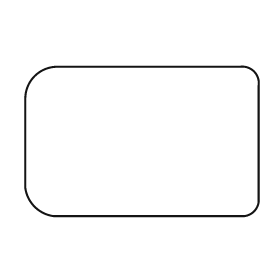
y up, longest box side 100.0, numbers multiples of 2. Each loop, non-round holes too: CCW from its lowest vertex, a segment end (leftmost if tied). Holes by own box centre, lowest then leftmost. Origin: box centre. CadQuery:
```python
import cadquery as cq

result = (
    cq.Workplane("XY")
    .moveTo(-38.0, -32.0)
    .lineTo(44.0, -32.0)
    .threePointArc((48.0, -30.0), (50.0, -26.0))
    .lineTo(50.0, 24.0)
    .threePointArc((48.0, 30.0), (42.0, 32.0))
    .lineTo(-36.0, 32.0)
    .threePointArc((-46.0, 28.0), (-50.0, 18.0))
    .lineTo(-50.0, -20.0)
    .threePointArc((-46.0, -28.0), (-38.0, -32.0))
    .close()
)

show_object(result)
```